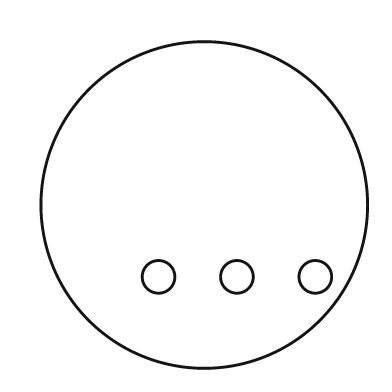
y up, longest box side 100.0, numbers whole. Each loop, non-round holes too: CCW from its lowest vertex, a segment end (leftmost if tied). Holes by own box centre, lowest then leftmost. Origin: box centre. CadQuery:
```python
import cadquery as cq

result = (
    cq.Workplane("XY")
    .moveTo(0.0, 0.0)
    .circle(50.0)
    .moveTo(-14.0, -22.0)
    .circle(5.0)
    .moveTo(10.0, -22.0)
    .circle(5.0)
    .moveTo(34.0, -22.0)
    .circle(5.0)
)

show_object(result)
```